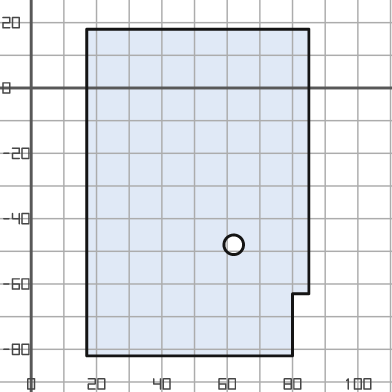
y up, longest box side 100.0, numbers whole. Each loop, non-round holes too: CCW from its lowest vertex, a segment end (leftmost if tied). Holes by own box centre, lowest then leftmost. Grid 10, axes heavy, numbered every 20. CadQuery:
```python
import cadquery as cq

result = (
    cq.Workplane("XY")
    .moveTo(17.0, -82.0)
    .lineTo(80.0, -82.0)
    .lineTo(80.0, -63.0)
    .lineTo(85.0, -63.0)
    .lineTo(85.0, 18.0)
    .lineTo(17.0, 18.0)
    .close()
    .moveTo(62.0, -48.0)
    .circle(3.0)
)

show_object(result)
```